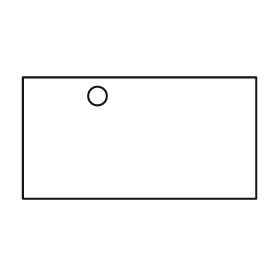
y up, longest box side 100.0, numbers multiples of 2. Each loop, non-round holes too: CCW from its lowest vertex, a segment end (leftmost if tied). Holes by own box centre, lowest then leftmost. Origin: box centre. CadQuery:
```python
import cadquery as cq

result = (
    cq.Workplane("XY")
    .moveTo(-50.0, -26.0)
    .lineTo(50.0, -26.0)
    .lineTo(50.0, 26.0)
    .lineTo(-50.0, 26.0)
    .close()
    .moveTo(-18.0, 18.0)
    .circle(4.0)
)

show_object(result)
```